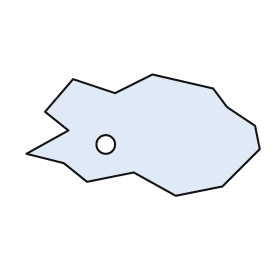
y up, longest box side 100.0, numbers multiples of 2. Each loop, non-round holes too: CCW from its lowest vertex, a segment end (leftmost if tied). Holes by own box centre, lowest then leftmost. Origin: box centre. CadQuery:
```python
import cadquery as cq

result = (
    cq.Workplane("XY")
    .moveTo(14.0, -26.0)
    .lineTo(34.0, -22.0)
    .lineTo(50.0, -6.0)
    .lineTo(48.0, 4.0)
    .lineTo(36.0, 12.0)
    .lineTo(30.0, 20.0)
    .lineTo(4.0, 26.0)
    .lineTo(-12.0, 18.0)
    .lineTo(-30.0, 24.0)
    .lineTo(-42.0, 10.0)
    .lineTo(-32.0, 2.0)
    .lineTo(-50.0, -8.0)
    .lineTo(-34.0, -12.0)
    .lineTo(-24.0, -20.0)
    .lineTo(-4.0, -16.0)
    .close()
    .moveTo(-16.0, -4.0)
    .circle(4.0)
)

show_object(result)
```